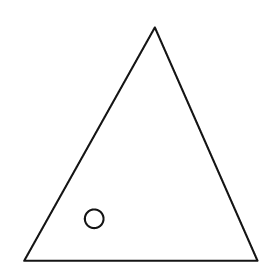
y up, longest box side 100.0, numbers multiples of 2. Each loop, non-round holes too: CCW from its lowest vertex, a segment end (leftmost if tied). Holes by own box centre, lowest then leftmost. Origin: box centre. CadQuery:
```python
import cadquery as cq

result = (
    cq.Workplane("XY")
    .moveTo(-50.0, -50.0)
    .lineTo(50.0, -50.0)
    .lineTo(6.0, 50.0)
    .close()
    .moveTo(-20.0, -32.0)
    .circle(4.0)
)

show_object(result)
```